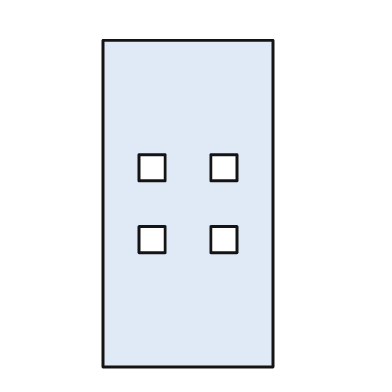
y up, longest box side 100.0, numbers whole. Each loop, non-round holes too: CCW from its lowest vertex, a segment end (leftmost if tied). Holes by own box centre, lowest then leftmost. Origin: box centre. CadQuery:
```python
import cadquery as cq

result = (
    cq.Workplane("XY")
    .moveTo(-26.0, -50.0)
    .lineTo(26.0, -50.0)
    .lineTo(26.0, 50.0)
    .lineTo(-26.0, 50.0)
    .close()
    .moveTo(-15.0, -15.0)
    .lineTo(-7.0, -15.0)
    .lineTo(-7.0, -7.0)
    .lineTo(-15.0, -7.0)
    .close()
    .moveTo(7.0, -15.0)
    .lineTo(15.0, -15.0)
    .lineTo(15.0, -7.0)
    .lineTo(7.0, -7.0)
    .close()
    .moveTo(-15.0, 7.0)
    .lineTo(-7.0, 7.0)
    .lineTo(-7.0, 15.0)
    .lineTo(-15.0, 15.0)
    .close()
    .moveTo(7.0, 7.0)
    .lineTo(15.0, 7.0)
    .lineTo(15.0, 15.0)
    .lineTo(7.0, 15.0)
    .close()
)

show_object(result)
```